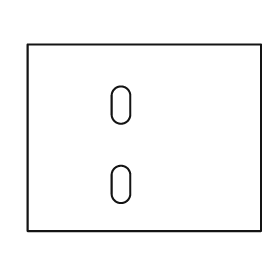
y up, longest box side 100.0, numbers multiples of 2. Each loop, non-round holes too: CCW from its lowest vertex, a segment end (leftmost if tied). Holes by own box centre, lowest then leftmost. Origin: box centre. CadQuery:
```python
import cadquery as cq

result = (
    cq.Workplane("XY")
    .moveTo(-50.0, -40.0)
    .lineTo(50.0, -40.0)
    .lineTo(50.0, 40.0)
    .lineTo(-50.0, 40.0)
    .close()
    .moveTo(-14.0, -24.0)
    .threePointArc((-10.0, -28.0), (-6.0, -24.0))
    .lineTo(-6.0, -16.0)
    .threePointArc((-10.0, -12.0), (-14.0, -16.0))
    .close()
    .moveTo(-14.0, 10.0)
    .threePointArc((-10.0, 6.0), (-6.0, 10.0))
    .lineTo(-6.0, 18.0)
    .threePointArc((-10.0, 22.0), (-14.0, 18.0))
    .close()
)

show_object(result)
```